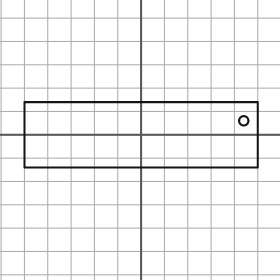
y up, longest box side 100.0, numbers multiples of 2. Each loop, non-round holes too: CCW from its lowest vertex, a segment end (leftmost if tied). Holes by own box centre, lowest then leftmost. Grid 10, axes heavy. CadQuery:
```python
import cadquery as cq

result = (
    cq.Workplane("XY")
    .moveTo(-50.0, -14.0)
    .lineTo(50.0, -14.0)
    .lineTo(50.0, 14.0)
    .lineTo(-50.0, 14.0)
    .close()
    .moveTo(44.0, 6.0)
    .circle(2.0)
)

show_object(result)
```